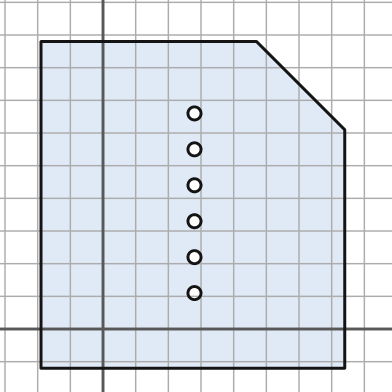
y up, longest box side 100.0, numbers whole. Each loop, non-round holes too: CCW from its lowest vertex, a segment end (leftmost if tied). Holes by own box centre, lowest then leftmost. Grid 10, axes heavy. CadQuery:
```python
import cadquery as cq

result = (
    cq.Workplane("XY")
    .moveTo(-19.0, -12.0)
    .lineTo(74.0, -12.0)
    .lineTo(74.0, 61.0)
    .lineTo(47.0, 88.0)
    .lineTo(-19.0, 88.0)
    .close()
    .moveTo(28.0, 11.0)
    .circle(2.0)
    .moveTo(28.0, 22.0)
    .circle(2.0)
    .moveTo(28.0, 33.0)
    .circle(2.0)
    .moveTo(28.0, 44.0)
    .circle(2.0)
    .moveTo(28.0, 55.0)
    .circle(2.0)
    .moveTo(28.0, 66.0)
    .circle(2.0)
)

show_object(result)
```